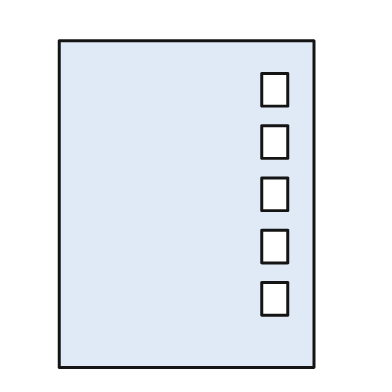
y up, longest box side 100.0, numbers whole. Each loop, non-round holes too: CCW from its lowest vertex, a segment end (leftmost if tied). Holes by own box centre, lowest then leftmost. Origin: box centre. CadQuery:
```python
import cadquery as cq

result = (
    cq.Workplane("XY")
    .moveTo(-39.0, -50.0)
    .lineTo(39.0, -50.0)
    .lineTo(39.0, 50.0)
    .lineTo(-39.0, 50.0)
    .close()
    .moveTo(23.0, -34.0)
    .lineTo(31.0, -34.0)
    .lineTo(31.0, -24.0)
    .lineTo(23.0, -24.0)
    .close()
    .moveTo(23.0, -18.0)
    .lineTo(31.0, -18.0)
    .lineTo(31.0, -8.0)
    .lineTo(23.0, -8.0)
    .close()
    .moveTo(23.0, -2.0)
    .lineTo(31.0, -2.0)
    .lineTo(31.0, 8.0)
    .lineTo(23.0, 8.0)
    .close()
    .moveTo(23.0, 14.0)
    .lineTo(31.0, 14.0)
    .lineTo(31.0, 24.0)
    .lineTo(23.0, 24.0)
    .close()
    .moveTo(23.0, 30.0)
    .lineTo(31.0, 30.0)
    .lineTo(31.0, 40.0)
    .lineTo(23.0, 40.0)
    .close()
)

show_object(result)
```